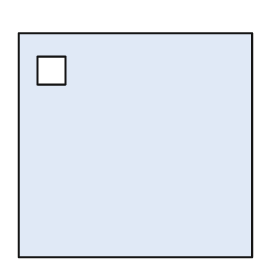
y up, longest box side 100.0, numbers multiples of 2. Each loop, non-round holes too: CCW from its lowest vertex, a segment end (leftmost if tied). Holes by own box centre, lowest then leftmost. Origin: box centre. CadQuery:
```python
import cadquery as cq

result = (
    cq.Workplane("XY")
    .moveTo(-50.0, -48.0)
    .lineTo(50.0, -48.0)
    .lineTo(50.0, 48.0)
    .lineTo(-50.0, 48.0)
    .close()
    .moveTo(-42.0, 26.0)
    .lineTo(-30.0, 26.0)
    .lineTo(-30.0, 38.0)
    .lineTo(-42.0, 38.0)
    .close()
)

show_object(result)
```